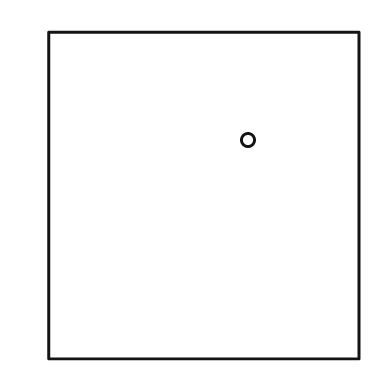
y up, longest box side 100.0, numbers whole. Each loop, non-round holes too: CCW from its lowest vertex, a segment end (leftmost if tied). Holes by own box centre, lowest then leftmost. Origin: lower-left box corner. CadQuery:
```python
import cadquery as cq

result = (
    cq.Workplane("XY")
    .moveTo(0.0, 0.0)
    .lineTo(95.0, 0.0)
    .lineTo(95.0, 100.0)
    .lineTo(0.0, 100.0)
    .close()
    .moveTo(61.0, 67.0)
    .circle(2.0)
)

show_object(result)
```